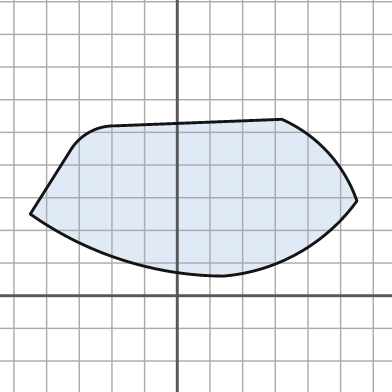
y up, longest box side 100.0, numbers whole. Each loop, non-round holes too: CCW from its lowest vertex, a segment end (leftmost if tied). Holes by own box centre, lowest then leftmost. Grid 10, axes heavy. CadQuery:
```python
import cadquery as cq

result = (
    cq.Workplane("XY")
    .moveTo(14.0, 6.0)
    .threePointArc((37.0, 13.0), (55.0, 29.0))
    .threePointArc((46.0, 44.0), (32.0, 54.0))
    .lineTo(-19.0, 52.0)
    .threePointArc((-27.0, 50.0), (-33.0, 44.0))
    .lineTo(-45.0, 25.0)
    .threePointArc((-17.0, 11.0), (14.0, 6.0))
    .close()
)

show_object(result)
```